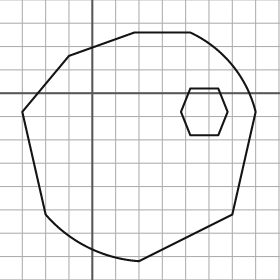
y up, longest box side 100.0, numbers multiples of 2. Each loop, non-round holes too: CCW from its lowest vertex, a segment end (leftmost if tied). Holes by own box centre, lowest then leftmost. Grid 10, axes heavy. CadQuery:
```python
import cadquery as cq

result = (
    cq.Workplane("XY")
    .moveTo(20.0, -72.0)
    .lineTo(60.0, -52.0)
    .lineTo(70.0, -8.0)
    .threePointArc((60.0, 12.0), (42.0, 26.0))
    .lineTo(18.0, 26.0)
    .lineTo(-10.0, 16.0)
    .lineTo(-30.0, -8.0)
    .lineTo(-20.0, -52.0)
    .threePointArc((-2.0, -66.0), (20.0, -72.0))
    .close()
    .moveTo(42.0, -18.0)
    .lineTo(54.0, -18.0)
    .lineTo(58.0, -8.0)
    .lineTo(54.0, 2.0)
    .lineTo(42.0, 2.0)
    .lineTo(38.0, -8.0)
    .close()
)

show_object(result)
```